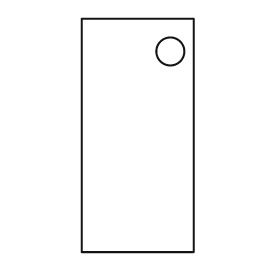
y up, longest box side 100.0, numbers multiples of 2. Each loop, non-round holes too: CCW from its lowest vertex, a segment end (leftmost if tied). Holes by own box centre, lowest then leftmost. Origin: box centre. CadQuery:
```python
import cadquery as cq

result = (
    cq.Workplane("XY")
    .moveTo(-24.0, -50.0)
    .lineTo(24.0, -50.0)
    .lineTo(24.0, 50.0)
    .lineTo(-24.0, 50.0)
    .close()
    .moveTo(14.0, 36.0)
    .circle(6.0)
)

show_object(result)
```